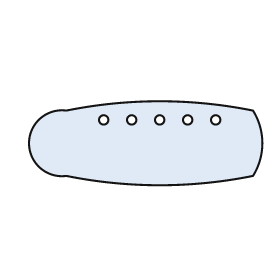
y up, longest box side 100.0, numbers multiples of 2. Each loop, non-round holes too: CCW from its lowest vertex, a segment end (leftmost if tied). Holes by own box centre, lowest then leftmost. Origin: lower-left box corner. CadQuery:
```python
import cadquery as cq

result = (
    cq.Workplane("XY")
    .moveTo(16.0, 4.0)
    .threePointArc((56.0, 0.0), (96.0, 4.0))
    .threePointArc((100.0, 18.0), (96.0, 32.0))
    .threePointArc((56.0, 36.0), (16.0, 32.0))
    .threePointArc((0.0, 18.0), (16.0, 4.0))
    .close()
    .moveTo(32.0, 28.0)
    .circle(2.0)
    .moveTo(44.0, 28.0)
    .circle(2.0)
    .moveTo(56.0, 28.0)
    .circle(2.0)
    .moveTo(68.0, 28.0)
    .circle(2.0)
    .moveTo(80.0, 28.0)
    .circle(2.0)
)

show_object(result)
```